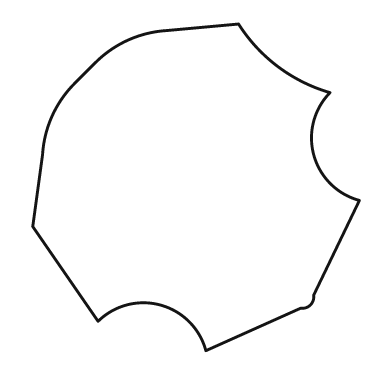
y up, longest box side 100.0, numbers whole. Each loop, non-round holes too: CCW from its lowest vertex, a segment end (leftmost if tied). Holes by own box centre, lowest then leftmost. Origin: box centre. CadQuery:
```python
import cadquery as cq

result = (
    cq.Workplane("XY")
    .moveTo(3.0, -50.0)
    .lineTo(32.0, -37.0)
    .threePointArc((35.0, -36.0), (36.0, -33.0))
    .lineTo(50.0, -4.0)
    .threePointArc((36.0, 10.0), (41.0, 29.0))
    .threePointArc((25.0, 37.0), (13.0, 50.0))
    .lineTo(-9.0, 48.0)
    .threePointArc((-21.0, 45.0), (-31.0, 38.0))
    .lineTo(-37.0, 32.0)
    .threePointArc((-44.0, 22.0), (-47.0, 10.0))
    .lineTo(-50.0, -12.0)
    .lineTo(-30.0, -41.0)
    .threePointArc((-11.0, -36.0), (3.0, -50.0))
    .close()
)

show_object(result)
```